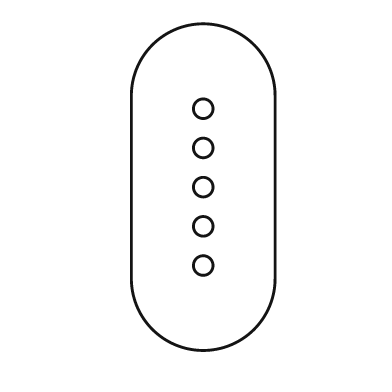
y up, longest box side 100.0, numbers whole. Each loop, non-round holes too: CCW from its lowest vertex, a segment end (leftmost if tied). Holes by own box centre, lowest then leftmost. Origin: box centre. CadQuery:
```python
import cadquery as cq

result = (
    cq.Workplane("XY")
    .moveTo(-22.0, -28.0)
    .threePointArc((0.0, -50.0), (22.0, -28.0))
    .lineTo(22.0, 28.0)
    .threePointArc((0.0, 50.0), (-22.0, 28.0))
    .close()
    .moveTo(0.0, -24.0)
    .circle(3.0)
    .moveTo(0.0, -12.0)
    .circle(3.0)
    .moveTo(0.0, 0.0)
    .circle(3.0)
    .moveTo(0.0, 12.0)
    .circle(3.0)
    .moveTo(0.0, 24.0)
    .circle(3.0)
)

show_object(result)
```